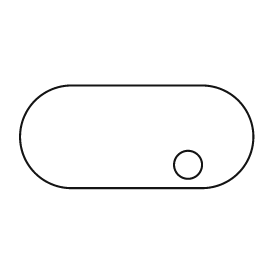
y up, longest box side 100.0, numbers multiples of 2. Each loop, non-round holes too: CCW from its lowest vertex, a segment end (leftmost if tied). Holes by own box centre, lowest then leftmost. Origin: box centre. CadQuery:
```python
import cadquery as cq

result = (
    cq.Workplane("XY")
    .moveTo(-28.0, -22.0)
    .lineTo(28.0, -22.0)
    .threePointArc((50.0, 0.0), (28.0, 22.0))
    .lineTo(-28.0, 22.0)
    .threePointArc((-50.0, 0.0), (-28.0, -22.0))
    .close()
    .moveTo(22.0, -12.0)
    .circle(6.0)
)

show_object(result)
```